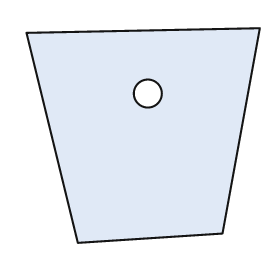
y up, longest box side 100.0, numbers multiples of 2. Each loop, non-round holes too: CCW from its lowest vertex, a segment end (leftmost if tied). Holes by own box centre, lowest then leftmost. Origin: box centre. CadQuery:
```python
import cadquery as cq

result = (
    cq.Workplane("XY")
    .moveTo(-28.0, -46.0)
    .lineTo(34.0, -42.0)
    .lineTo(50.0, 46.0)
    .lineTo(-50.0, 44.0)
    .close()
    .moveTo(2.0, 18.0)
    .circle(6.0)
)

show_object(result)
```